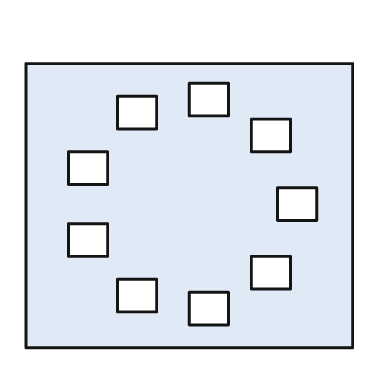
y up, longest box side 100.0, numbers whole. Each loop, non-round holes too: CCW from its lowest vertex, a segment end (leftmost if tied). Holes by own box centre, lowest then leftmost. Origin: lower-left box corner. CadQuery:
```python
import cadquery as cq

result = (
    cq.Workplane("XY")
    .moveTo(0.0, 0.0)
    .lineTo(100.0, 0.0)
    .lineTo(100.0, 87.0)
    .lineTo(0.0, 87.0)
    .close()
    .moveTo(50.0, 7.0)
    .lineTo(62.0, 7.0)
    .lineTo(62.0, 17.0)
    .lineTo(50.0, 17.0)
    .close()
    .moveTo(28.0, 11.0)
    .lineTo(40.0, 11.0)
    .lineTo(40.0, 21.0)
    .lineTo(28.0, 21.0)
    .close()
    .moveTo(69.0, 18.0)
    .lineTo(81.0, 18.0)
    .lineTo(81.0, 28.0)
    .lineTo(69.0, 28.0)
    .close()
    .moveTo(13.0, 28.0)
    .lineTo(25.0, 28.0)
    .lineTo(25.0, 38.0)
    .lineTo(13.0, 38.0)
    .close()
    .moveTo(77.0, 39.0)
    .lineTo(89.0, 39.0)
    .lineTo(89.0, 49.0)
    .lineTo(77.0, 49.0)
    .close()
    .moveTo(13.0, 50.0)
    .lineTo(25.0, 50.0)
    .lineTo(25.0, 60.0)
    .lineTo(13.0, 60.0)
    .close()
    .moveTo(69.0, 60.0)
    .lineTo(81.0, 60.0)
    .lineTo(81.0, 70.0)
    .lineTo(69.0, 70.0)
    .close()
    .moveTo(28.0, 67.0)
    .lineTo(40.0, 67.0)
    .lineTo(40.0, 77.0)
    .lineTo(28.0, 77.0)
    .close()
    .moveTo(50.0, 71.0)
    .lineTo(62.0, 71.0)
    .lineTo(62.0, 81.0)
    .lineTo(50.0, 81.0)
    .close()
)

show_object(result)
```